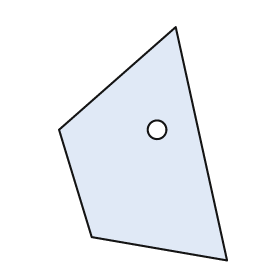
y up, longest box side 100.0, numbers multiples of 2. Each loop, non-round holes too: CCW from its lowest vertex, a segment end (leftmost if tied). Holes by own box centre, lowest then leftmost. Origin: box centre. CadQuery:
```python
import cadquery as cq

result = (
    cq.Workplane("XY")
    .moveTo(36.0, -50.0)
    .lineTo(14.0, 50.0)
    .lineTo(-36.0, 6.0)
    .lineTo(-22.0, -40.0)
    .close()
    .moveTo(6.0, 6.0)
    .circle(4.0)
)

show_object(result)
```